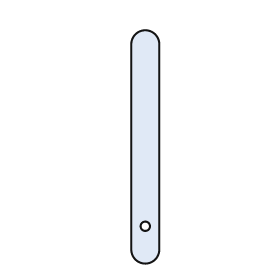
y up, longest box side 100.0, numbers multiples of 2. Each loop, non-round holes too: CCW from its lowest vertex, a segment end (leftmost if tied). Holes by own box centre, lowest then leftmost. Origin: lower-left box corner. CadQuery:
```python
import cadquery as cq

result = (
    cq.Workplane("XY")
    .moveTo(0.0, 6.0)
    .threePointArc((6.0, 0.0), (12.0, 6.0))
    .lineTo(12.0, 94.0)
    .threePointArc((6.0, 100.0), (0.0, 94.0))
    .close()
    .moveTo(6.0, 16.0)
    .circle(2.0)
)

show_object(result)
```